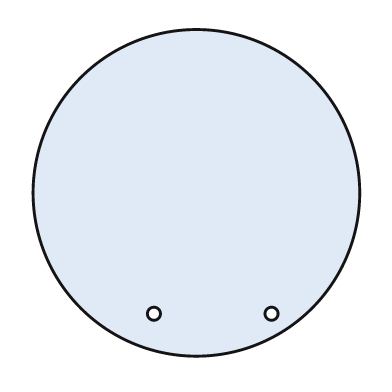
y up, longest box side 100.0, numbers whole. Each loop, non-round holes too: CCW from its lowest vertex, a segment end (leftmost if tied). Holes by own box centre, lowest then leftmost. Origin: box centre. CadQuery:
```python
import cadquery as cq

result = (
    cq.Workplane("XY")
    .moveTo(0.0, 0.0)
    .circle(50.0)
    .moveTo(-13.0, -37.0)
    .circle(2.0)
    .moveTo(23.0, -37.0)
    .circle(2.0)
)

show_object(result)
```